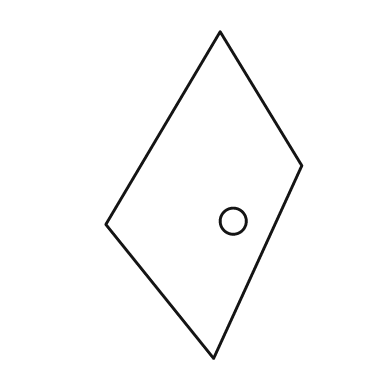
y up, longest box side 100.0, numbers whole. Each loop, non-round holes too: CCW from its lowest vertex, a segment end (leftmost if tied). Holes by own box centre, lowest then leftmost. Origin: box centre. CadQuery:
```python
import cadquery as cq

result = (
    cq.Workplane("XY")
    .moveTo(3.0, -50.0)
    .lineTo(30.0, 9.0)
    .lineTo(5.0, 50.0)
    .lineTo(-30.0, -9.0)
    .close()
    .moveTo(9.0, -8.0)
    .circle(4.0)
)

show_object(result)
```